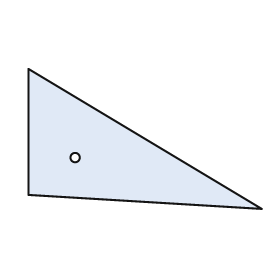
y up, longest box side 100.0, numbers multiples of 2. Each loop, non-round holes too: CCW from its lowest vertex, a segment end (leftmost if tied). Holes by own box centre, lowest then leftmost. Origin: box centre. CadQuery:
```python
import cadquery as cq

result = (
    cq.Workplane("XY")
    .moveTo(50.0, -30.0)
    .lineTo(-50.0, 30.0)
    .lineTo(-50.0, -24.0)
    .close()
    .moveTo(-30.0, -8.0)
    .circle(2.0)
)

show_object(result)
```